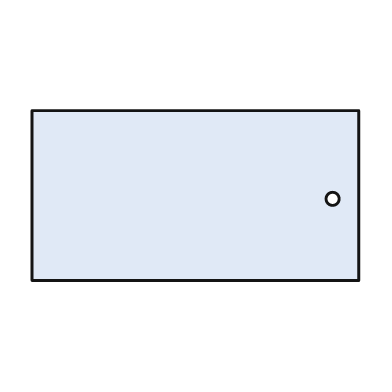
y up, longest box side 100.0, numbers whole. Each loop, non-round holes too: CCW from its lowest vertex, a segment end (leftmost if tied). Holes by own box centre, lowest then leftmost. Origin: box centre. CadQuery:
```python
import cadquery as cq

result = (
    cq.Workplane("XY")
    .moveTo(-50.0, -26.0)
    .lineTo(50.0, -26.0)
    .lineTo(50.0, 26.0)
    .lineTo(-50.0, 26.0)
    .close()
    .moveTo(42.0, -1.0)
    .circle(2.0)
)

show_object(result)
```